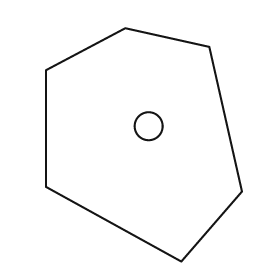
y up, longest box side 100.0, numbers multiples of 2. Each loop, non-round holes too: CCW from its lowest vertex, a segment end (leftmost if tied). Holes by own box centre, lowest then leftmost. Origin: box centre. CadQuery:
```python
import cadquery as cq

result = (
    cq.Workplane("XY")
    .moveTo(16.0, -50.0)
    .lineTo(42.0, -20.0)
    .lineTo(28.0, 42.0)
    .lineTo(-8.0, 50.0)
    .lineTo(-42.0, 32.0)
    .lineTo(-42.0, -18.0)
    .close()
    .moveTo(2.0, 8.0)
    .circle(6.0)
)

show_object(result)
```